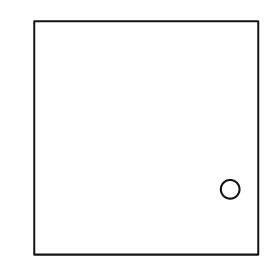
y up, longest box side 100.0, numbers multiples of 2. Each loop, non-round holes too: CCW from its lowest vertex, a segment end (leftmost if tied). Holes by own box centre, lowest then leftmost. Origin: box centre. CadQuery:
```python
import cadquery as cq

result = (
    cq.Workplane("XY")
    .moveTo(-48.0, -50.0)
    .lineTo(48.0, -50.0)
    .lineTo(48.0, 50.0)
    .lineTo(-48.0, 50.0)
    .close()
    .moveTo(36.0, -22.0)
    .circle(4.0)
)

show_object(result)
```